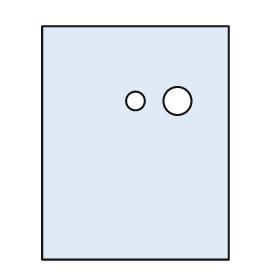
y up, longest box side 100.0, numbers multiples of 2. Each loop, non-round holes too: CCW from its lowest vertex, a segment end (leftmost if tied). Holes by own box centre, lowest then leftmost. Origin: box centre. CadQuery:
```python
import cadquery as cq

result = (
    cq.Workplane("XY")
    .moveTo(-40.0, -50.0)
    .lineTo(40.0, -50.0)
    .lineTo(40.0, 50.0)
    .lineTo(-40.0, 50.0)
    .close()
    .moveTo(0.0, 18.0)
    .circle(4.0)
    .moveTo(18.0, 18.0)
    .circle(6.0)
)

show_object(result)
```